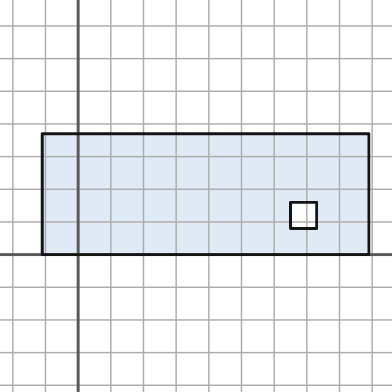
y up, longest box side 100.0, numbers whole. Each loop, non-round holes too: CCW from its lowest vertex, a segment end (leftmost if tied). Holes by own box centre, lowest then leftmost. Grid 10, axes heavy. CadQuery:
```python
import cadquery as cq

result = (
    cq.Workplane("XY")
    .moveTo(-11.0, 0.0)
    .lineTo(89.0, 0.0)
    .lineTo(89.0, 37.0)
    .lineTo(-11.0, 37.0)
    .close()
    .moveTo(65.0, 8.0)
    .lineTo(73.0, 8.0)
    .lineTo(73.0, 16.0)
    .lineTo(65.0, 16.0)
    .close()
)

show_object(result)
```